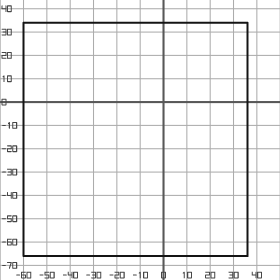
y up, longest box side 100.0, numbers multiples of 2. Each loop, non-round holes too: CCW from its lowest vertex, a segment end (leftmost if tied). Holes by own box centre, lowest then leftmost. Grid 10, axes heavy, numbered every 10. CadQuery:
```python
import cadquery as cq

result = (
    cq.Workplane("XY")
    .moveTo(-60.0, -66.0)
    .lineTo(36.0, -66.0)
    .lineTo(36.0, 34.0)
    .lineTo(-60.0, 34.0)
    .close()
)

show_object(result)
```